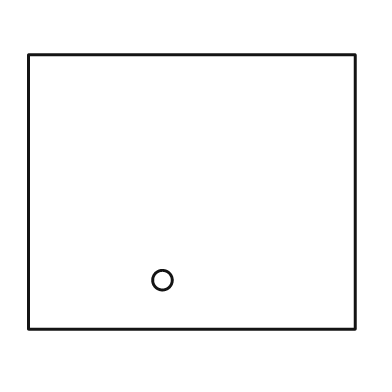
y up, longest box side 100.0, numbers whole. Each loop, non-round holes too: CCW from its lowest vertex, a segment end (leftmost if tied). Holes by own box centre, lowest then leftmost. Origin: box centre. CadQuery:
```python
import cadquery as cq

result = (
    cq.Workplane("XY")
    .moveTo(-50.0, -42.0)
    .lineTo(50.0, -42.0)
    .lineTo(50.0, 42.0)
    .lineTo(-50.0, 42.0)
    .close()
    .moveTo(-9.0, -27.0)
    .circle(3.0)
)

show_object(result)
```